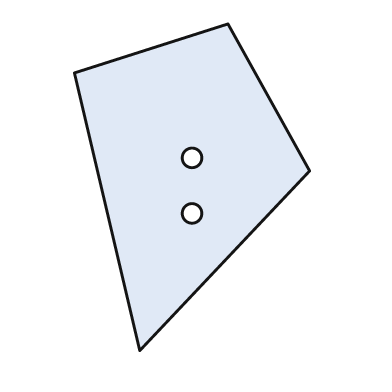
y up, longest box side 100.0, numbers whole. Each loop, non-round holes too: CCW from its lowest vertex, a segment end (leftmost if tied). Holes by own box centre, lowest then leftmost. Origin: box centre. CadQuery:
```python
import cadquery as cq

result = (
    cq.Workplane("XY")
    .moveTo(-16.0, -50.0)
    .lineTo(36.0, 5.0)
    .lineTo(11.0, 50.0)
    .lineTo(-36.0, 35.0)
    .close()
    .moveTo(0.0, -8.0)
    .circle(3.0)
    .moveTo(0.0, 9.0)
    .circle(3.0)
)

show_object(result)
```